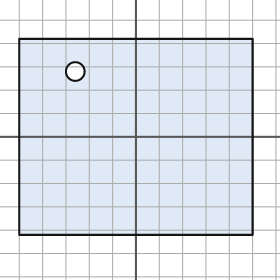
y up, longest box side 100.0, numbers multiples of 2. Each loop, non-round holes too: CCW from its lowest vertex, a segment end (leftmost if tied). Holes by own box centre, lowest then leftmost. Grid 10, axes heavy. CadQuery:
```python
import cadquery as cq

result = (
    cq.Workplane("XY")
    .moveTo(-50.0, -42.0)
    .lineTo(50.0, -42.0)
    .lineTo(50.0, 42.0)
    .lineTo(-50.0, 42.0)
    .close()
    .moveTo(-26.0, 28.0)
    .circle(4.0)
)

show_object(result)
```